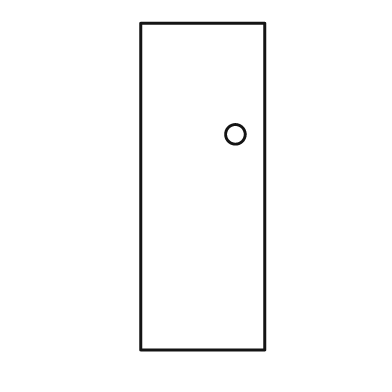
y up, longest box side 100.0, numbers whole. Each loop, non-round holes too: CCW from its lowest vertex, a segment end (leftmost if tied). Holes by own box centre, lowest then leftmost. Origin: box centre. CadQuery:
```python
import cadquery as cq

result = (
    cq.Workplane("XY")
    .moveTo(-19.0, -50.0)
    .lineTo(19.0, -50.0)
    .lineTo(19.0, 50.0)
    .lineTo(-19.0, 50.0)
    .close()
    .moveTo(10.0, 16.0)
    .circle(3.0)
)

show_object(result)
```